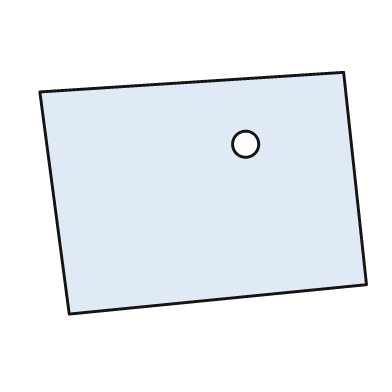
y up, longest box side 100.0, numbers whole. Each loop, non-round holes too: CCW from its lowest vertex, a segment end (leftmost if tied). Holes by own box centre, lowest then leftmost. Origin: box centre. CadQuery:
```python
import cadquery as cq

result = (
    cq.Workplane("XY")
    .moveTo(-41.0, -37.0)
    .lineTo(50.0, -28.0)
    .lineTo(43.0, 37.0)
    .lineTo(-50.0, 31.0)
    .close()
    .moveTo(13.0, 15.0)
    .circle(4.0)
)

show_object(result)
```